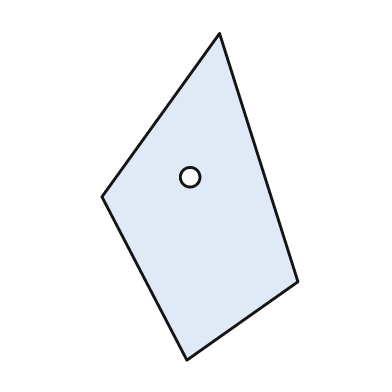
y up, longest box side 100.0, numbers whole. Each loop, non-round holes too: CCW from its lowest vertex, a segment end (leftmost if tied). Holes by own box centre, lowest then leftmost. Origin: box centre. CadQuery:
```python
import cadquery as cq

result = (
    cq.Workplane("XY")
    .moveTo(-4.0, -50.0)
    .lineTo(30.0, -26.0)
    .lineTo(6.0, 50.0)
    .lineTo(-30.0, 0.0)
    .close()
    .moveTo(-3.0, 6.0)
    .circle(3.0)
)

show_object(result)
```